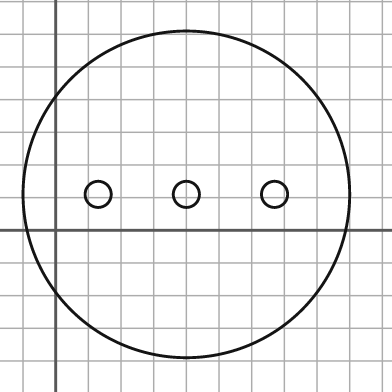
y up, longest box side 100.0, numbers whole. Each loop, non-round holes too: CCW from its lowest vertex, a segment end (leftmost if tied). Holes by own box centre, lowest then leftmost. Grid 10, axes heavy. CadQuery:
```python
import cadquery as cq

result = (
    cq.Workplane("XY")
    .moveTo(40.0, 11.0)
    .circle(50.0)
    .moveTo(13.0, 11.0)
    .circle(4.0)
    .moveTo(40.0, 11.0)
    .circle(4.0)
    .moveTo(67.0, 11.0)
    .circle(4.0)
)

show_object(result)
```